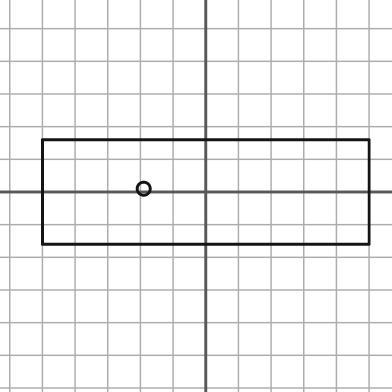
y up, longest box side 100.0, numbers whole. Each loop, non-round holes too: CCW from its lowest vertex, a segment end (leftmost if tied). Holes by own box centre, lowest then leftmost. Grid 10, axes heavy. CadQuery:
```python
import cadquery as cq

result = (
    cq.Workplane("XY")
    .moveTo(-50.0, -16.0)
    .lineTo(50.0, -16.0)
    .lineTo(50.0, 16.0)
    .lineTo(-50.0, 16.0)
    .close()
    .moveTo(-19.0, 1.0)
    .circle(2.0)
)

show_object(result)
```